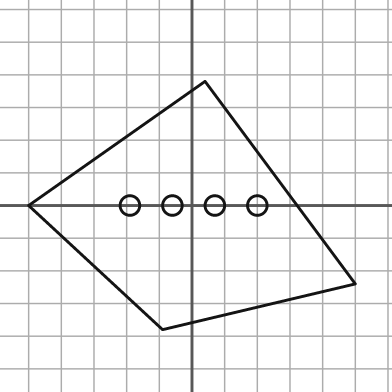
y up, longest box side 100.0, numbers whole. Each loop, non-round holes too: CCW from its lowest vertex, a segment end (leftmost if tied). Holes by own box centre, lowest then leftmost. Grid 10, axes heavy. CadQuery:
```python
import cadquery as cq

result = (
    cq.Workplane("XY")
    .moveTo(-9.0, -38.0)
    .lineTo(50.0, -24.0)
    .lineTo(4.0, 38.0)
    .lineTo(-50.0, 0.0)
    .close()
    .moveTo(-19.0, 0.0)
    .circle(3.0)
    .moveTo(-6.0, 0.0)
    .circle(3.0)
    .moveTo(7.0, 0.0)
    .circle(3.0)
    .moveTo(20.0, 0.0)
    .circle(3.0)
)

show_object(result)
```